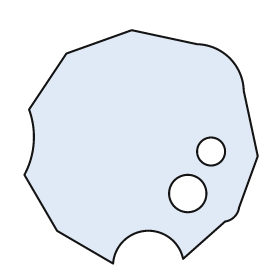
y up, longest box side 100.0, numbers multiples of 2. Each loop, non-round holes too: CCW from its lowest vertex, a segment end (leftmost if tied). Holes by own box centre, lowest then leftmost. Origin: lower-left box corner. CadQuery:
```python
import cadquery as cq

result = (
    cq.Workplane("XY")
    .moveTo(38.0, 0.0)
    .threePointArc((52.0, 14.0), (68.0, 2.0))
    .lineTo(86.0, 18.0)
    .threePointArc((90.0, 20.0), (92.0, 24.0))
    .lineTo(100.0, 46.0)
    .lineTo(94.0, 74.0)
    .threePointArc((88.0, 88.0), (74.0, 94.0))
    .lineTo(46.0, 100.0)
    .lineTo(18.0, 90.0)
    .lineTo(2.0, 66.0)
    .threePointArc((4.0, 52.0), (0.0, 38.0))
    .lineTo(14.0, 14.0)
    .close()
    .moveTo(70.0, 30.0)
    .circle(8.0)
    .moveTo(80.0, 48.0)
    .circle(6.0)
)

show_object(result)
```